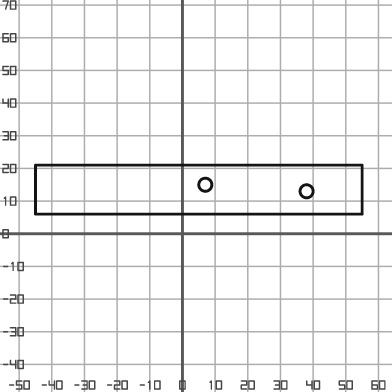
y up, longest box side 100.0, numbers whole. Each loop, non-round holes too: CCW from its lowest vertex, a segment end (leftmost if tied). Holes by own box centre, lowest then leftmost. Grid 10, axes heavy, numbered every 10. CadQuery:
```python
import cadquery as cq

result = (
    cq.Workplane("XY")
    .moveTo(-45.0, 6.0)
    .lineTo(55.0, 6.0)
    .lineTo(55.0, 21.0)
    .lineTo(-45.0, 21.0)
    .close()
    .moveTo(38.0, 13.0)
    .circle(2.0)
    .moveTo(7.0, 15.0)
    .circle(2.0)
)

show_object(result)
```